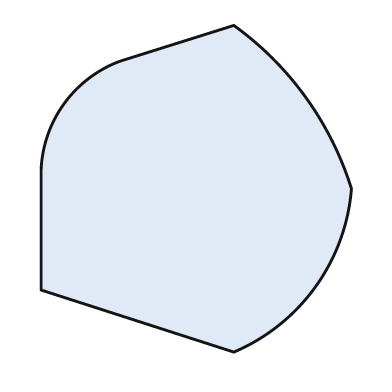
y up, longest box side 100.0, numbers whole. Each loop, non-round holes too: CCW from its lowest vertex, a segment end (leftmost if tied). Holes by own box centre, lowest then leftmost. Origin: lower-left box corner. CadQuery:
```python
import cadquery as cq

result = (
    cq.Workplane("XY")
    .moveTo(59.0, 0.0)
    .threePointArc((84.0, 20.0), (95.0, 50.0))
    .threePointArc((81.0, 78.0), (59.0, 100.0))
    .lineTo(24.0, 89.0)
    .threePointArc((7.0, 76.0), (0.0, 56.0))
    .lineTo(0.0, 19.0)
    .close()
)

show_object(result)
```